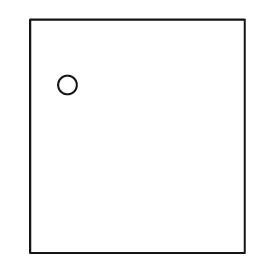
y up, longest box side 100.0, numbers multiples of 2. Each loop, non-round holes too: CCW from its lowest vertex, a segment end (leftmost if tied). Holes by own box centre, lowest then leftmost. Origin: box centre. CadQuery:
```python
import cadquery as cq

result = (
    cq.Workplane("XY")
    .moveTo(-46.0, -50.0)
    .lineTo(46.0, -50.0)
    .lineTo(46.0, 50.0)
    .lineTo(-46.0, 50.0)
    .close()
    .moveTo(-30.0, 22.0)
    .circle(4.0)
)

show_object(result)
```